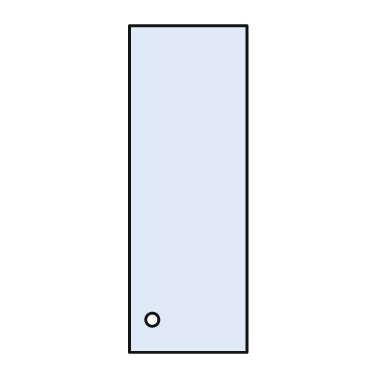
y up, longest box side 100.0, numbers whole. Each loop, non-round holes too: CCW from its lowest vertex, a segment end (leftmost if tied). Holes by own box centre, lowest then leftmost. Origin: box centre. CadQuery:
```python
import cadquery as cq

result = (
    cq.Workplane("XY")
    .moveTo(-18.0, -50.0)
    .lineTo(18.0, -50.0)
    .lineTo(18.0, 50.0)
    .lineTo(-18.0, 50.0)
    .close()
    .moveTo(-11.0, -40.0)
    .circle(2.0)
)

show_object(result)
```